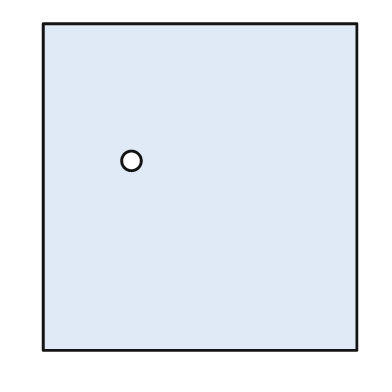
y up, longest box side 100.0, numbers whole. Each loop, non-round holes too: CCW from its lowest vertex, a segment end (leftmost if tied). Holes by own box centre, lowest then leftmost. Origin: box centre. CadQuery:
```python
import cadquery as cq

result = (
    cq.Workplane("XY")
    .moveTo(-48.0, -50.0)
    .lineTo(48.0, -50.0)
    .lineTo(48.0, 50.0)
    .lineTo(-48.0, 50.0)
    .close()
    .moveTo(-21.0, 8.0)
    .circle(3.0)
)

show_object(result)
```